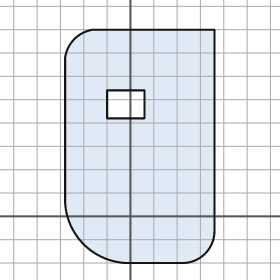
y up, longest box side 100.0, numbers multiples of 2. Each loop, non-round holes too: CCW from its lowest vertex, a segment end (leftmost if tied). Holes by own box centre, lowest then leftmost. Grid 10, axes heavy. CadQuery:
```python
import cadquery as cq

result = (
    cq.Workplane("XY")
    .moveTo(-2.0, -20.0)
    .lineTo(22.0, -20.0)
    .threePointArc((32.0, -16.0), (36.0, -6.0))
    .lineTo(36.0, 80.0)
    .lineTo(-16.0, 80.0)
    .threePointArc((-24.0, 76.0), (-28.0, 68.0))
    .lineTo(-28.0, 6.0)
    .threePointArc((-20.0, -12.0), (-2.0, -20.0))
    .close()
    .moveTo(-10.0, 42.0)
    .lineTo(6.0, 42.0)
    .lineTo(6.0, 54.0)
    .lineTo(-10.0, 54.0)
    .close()
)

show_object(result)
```